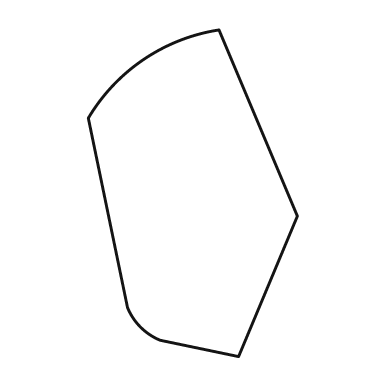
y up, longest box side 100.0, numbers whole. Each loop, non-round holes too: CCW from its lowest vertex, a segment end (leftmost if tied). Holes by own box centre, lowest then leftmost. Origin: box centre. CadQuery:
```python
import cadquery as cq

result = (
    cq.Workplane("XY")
    .moveTo(14.0, -50.0)
    .lineTo(32.0, -7.0)
    .lineTo(8.0, 50.0)
    .threePointArc((-15.0, 41.0), (-32.0, 23.0))
    .lineTo(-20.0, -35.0)
    .threePointArc((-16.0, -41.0), (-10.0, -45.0))
    .close()
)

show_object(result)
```